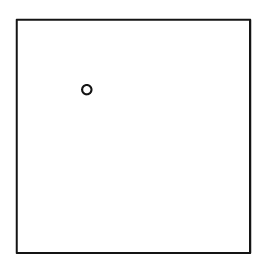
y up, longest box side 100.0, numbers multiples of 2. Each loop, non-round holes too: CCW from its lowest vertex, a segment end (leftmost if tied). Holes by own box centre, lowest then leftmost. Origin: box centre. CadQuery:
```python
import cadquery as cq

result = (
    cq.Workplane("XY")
    .moveTo(-50.0, -50.0)
    .lineTo(50.0, -50.0)
    .lineTo(50.0, 50.0)
    .lineTo(-50.0, 50.0)
    .close()
    .moveTo(-20.0, 20.0)
    .circle(2.0)
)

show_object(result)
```